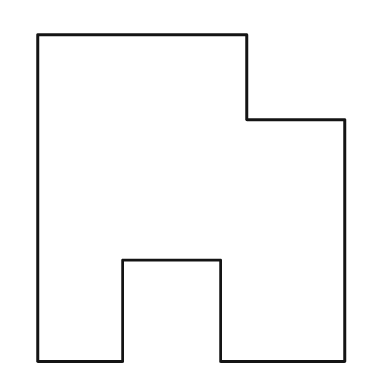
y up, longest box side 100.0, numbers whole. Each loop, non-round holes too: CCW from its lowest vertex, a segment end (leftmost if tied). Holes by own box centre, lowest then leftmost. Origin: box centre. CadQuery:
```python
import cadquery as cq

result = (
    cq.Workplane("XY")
    .moveTo(-47.0, -50.0)
    .lineTo(-21.0, -50.0)
    .lineTo(-21.0, -19.0)
    .lineTo(9.0, -19.0)
    .lineTo(9.0, -50.0)
    .lineTo(47.0, -50.0)
    .lineTo(47.0, 24.0)
    .lineTo(17.0, 24.0)
    .lineTo(17.0, 50.0)
    .lineTo(-47.0, 50.0)
    .close()
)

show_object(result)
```